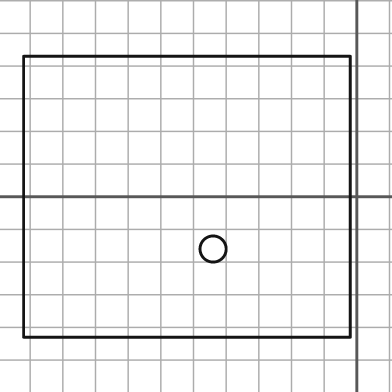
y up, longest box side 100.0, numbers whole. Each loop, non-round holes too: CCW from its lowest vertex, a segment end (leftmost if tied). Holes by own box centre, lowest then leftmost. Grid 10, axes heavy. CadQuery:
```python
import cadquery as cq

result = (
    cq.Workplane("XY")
    .moveTo(-102.0, -43.0)
    .lineTo(-2.0, -43.0)
    .lineTo(-2.0, 43.0)
    .lineTo(-102.0, 43.0)
    .close()
    .moveTo(-44.0, -16.0)
    .circle(4.0)
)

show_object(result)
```